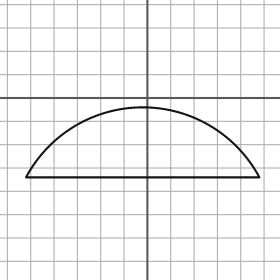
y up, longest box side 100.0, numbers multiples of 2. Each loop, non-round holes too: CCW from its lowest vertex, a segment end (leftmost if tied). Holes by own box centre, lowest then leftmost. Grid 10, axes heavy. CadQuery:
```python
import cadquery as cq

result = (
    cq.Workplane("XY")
    .moveTo(-52.0, -34.0)
    .lineTo(48.0, -34.0)
    .threePointArc((-2.0, -4.0), (-52.0, -34.0))
    .close()
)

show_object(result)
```